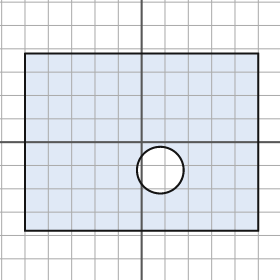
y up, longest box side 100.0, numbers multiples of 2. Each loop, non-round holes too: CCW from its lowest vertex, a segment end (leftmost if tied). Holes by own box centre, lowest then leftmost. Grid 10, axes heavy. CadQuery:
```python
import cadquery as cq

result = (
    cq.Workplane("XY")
    .moveTo(-50.0, -38.0)
    .lineTo(50.0, -38.0)
    .lineTo(50.0, 38.0)
    .lineTo(-50.0, 38.0)
    .close()
    .moveTo(8.0, -12.0)
    .circle(10.0)
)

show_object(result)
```